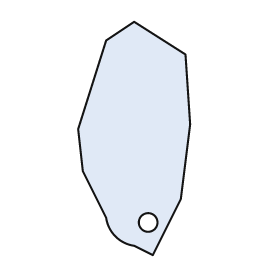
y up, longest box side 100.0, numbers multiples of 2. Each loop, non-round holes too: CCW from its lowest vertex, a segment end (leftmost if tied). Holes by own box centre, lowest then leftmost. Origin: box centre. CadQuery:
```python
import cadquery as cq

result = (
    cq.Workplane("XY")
    .moveTo(8.0, -50.0)
    .lineTo(20.0, -26.0)
    .lineTo(24.0, 6.0)
    .lineTo(22.0, 36.0)
    .lineTo(0.0, 50.0)
    .lineTo(-12.0, 42.0)
    .lineTo(-24.0, 4.0)
    .lineTo(-22.0, -14.0)
    .lineTo(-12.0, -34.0)
    .threePointArc((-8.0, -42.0), (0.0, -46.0))
    .close()
    .moveTo(6.0, -36.0)
    .circle(4.0)
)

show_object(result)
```